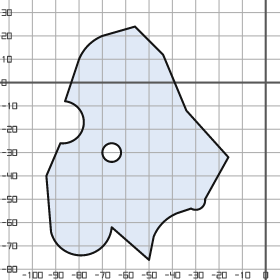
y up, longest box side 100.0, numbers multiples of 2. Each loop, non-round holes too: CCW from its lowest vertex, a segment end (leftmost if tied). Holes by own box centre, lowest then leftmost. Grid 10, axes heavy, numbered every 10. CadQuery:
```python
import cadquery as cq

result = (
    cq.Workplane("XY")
    .moveTo(-50.0, -76.0)
    .lineTo(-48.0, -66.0)
    .threePointArc((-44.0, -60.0), (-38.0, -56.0))
    .lineTo(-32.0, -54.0)
    .threePointArc((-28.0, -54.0), (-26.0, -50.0))
    .lineTo(-16.0, -32.0)
    .lineTo(-34.0, -12.0)
    .lineTo(-44.0, 12.0)
    .lineTo(-56.0, 24.0)
    .lineTo(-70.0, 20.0)
    .threePointArc((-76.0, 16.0), (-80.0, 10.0))
    .lineTo(-86.0, -8.0)
    .threePointArc((-78.0, -18.0), (-88.0, -26.0))
    .lineTo(-94.0, -40.0)
    .lineTo(-92.0, -64.0)
    .threePointArc((-78.0, -74.0), (-66.0, -62.0))
    .close()
    .moveTo(-66.0, -30.0)
    .circle(4.0)
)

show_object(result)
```